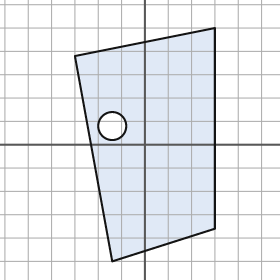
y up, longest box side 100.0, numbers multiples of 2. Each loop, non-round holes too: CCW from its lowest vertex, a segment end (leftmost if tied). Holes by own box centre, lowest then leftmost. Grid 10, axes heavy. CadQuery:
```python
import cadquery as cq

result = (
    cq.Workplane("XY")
    .moveTo(-14.0, -50.0)
    .lineTo(30.0, -36.0)
    .lineTo(30.0, 50.0)
    .lineTo(-30.0, 38.0)
    .close()
    .moveTo(-14.0, 8.0)
    .circle(6.0)
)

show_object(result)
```